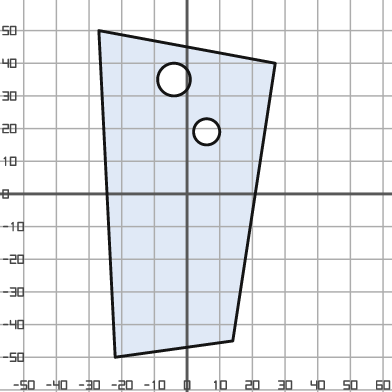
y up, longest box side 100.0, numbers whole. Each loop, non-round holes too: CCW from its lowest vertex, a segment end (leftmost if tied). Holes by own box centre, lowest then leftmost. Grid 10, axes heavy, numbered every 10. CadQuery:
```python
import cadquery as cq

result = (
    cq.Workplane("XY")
    .moveTo(-22.0, -50.0)
    .lineTo(14.0, -45.0)
    .lineTo(27.0, 40.0)
    .lineTo(-27.0, 50.0)
    .close()
    .moveTo(6.0, 19.0)
    .circle(4.0)
    .moveTo(-4.0, 35.0)
    .circle(5.0)
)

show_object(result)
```